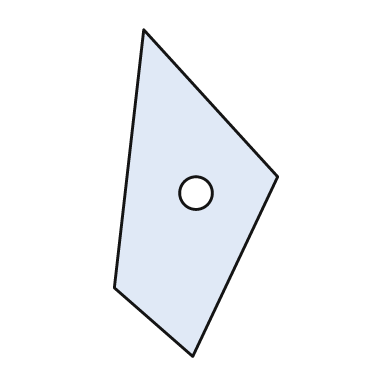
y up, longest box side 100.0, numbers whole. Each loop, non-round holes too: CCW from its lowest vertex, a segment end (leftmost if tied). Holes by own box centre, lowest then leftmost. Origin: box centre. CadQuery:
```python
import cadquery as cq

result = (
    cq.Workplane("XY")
    .moveTo(-1.0, -50.0)
    .lineTo(25.0, 5.0)
    .lineTo(-16.0, 50.0)
    .lineTo(-25.0, -29.0)
    .close()
    .moveTo(0.0, 0.0)
    .circle(5.0)
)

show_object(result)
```